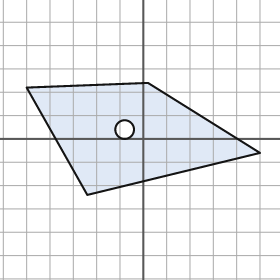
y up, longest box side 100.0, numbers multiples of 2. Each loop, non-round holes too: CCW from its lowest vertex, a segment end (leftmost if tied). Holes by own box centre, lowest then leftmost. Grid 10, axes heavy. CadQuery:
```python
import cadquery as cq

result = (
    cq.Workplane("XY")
    .moveTo(-24.0, -24.0)
    .lineTo(50.0, -6.0)
    .lineTo(2.0, 24.0)
    .lineTo(-50.0, 22.0)
    .close()
    .moveTo(-8.0, 4.0)
    .circle(4.0)
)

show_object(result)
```